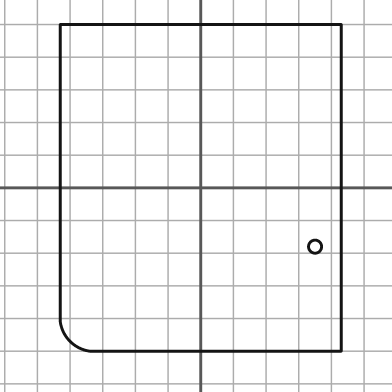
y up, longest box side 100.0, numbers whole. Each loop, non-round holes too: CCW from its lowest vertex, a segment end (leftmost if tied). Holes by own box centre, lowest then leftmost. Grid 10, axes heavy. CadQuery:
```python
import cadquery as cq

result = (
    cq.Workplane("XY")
    .moveTo(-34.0, -50.0)
    .lineTo(43.0, -50.0)
    .lineTo(43.0, 50.0)
    .lineTo(-43.0, 50.0)
    .lineTo(-43.0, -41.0)
    .threePointArc((-40.0, -47.0), (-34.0, -50.0))
    .close()
    .moveTo(35.0, -18.0)
    .circle(2.0)
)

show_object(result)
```